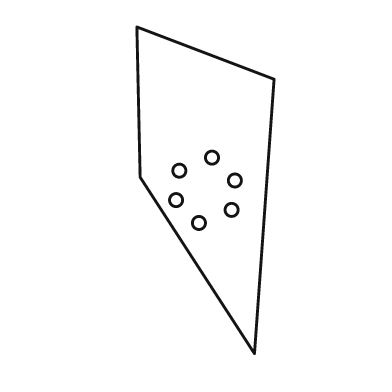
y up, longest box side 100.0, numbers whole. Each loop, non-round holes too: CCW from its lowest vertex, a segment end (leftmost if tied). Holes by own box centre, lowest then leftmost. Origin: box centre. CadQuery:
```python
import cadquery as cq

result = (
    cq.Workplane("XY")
    .moveTo(15.0, -50.0)
    .lineTo(21.0, 34.0)
    .lineTo(-21.0, 50.0)
    .lineTo(-20.0, 4.0)
    .close()
    .moveTo(-2.0, -10.0)
    .circle(2.0)
    .moveTo(8.0, -6.0)
    .circle(2.0)
    .moveTo(-9.0, -3.0)
    .circle(2.0)
    .moveTo(9.0, 3.0)
    .circle(2.0)
    .moveTo(-8.0, 6.0)
    .circle(2.0)
    .moveTo(2.0, 10.0)
    .circle(2.0)
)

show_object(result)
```